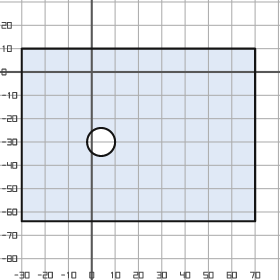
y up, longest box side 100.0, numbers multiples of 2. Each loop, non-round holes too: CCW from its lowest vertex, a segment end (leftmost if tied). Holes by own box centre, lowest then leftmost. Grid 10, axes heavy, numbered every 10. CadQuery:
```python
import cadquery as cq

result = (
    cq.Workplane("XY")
    .moveTo(-30.0, -64.0)
    .lineTo(70.0, -64.0)
    .lineTo(70.0, 10.0)
    .lineTo(-30.0, 10.0)
    .close()
    .moveTo(4.0, -30.0)
    .circle(6.0)
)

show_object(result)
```